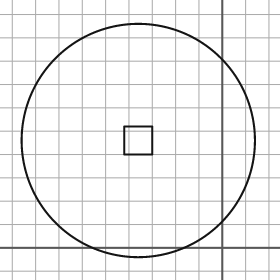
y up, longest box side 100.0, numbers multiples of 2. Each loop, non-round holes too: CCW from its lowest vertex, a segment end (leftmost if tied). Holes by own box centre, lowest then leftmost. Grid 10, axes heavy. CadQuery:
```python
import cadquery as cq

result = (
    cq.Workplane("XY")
    .moveTo(-36.0, 46.0)
    .circle(50.0)
    .moveTo(-42.0, 40.0)
    .lineTo(-30.0, 40.0)
    .lineTo(-30.0, 52.0)
    .lineTo(-42.0, 52.0)
    .close()
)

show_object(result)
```